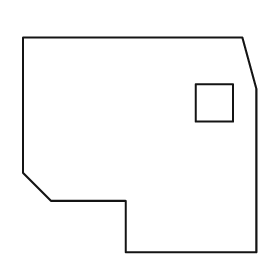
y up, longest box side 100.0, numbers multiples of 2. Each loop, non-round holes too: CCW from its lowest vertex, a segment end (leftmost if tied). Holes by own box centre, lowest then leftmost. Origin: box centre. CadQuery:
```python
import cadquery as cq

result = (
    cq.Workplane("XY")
    .moveTo(-6.0, -46.0)
    .lineTo(50.0, -46.0)
    .lineTo(50.0, 24.0)
    .lineTo(44.0, 46.0)
    .lineTo(-50.0, 46.0)
    .lineTo(-50.0, -12.0)
    .lineTo(-38.0, -24.0)
    .lineTo(-6.0, -24.0)
    .close()
    .moveTo(24.0, 10.0)
    .lineTo(40.0, 10.0)
    .lineTo(40.0, 26.0)
    .lineTo(24.0, 26.0)
    .close()
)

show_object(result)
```